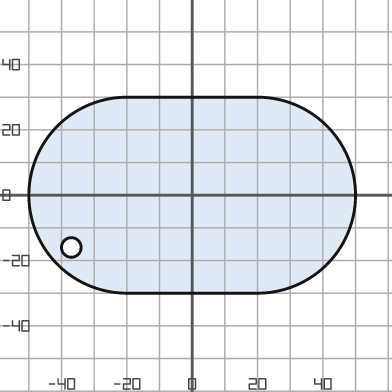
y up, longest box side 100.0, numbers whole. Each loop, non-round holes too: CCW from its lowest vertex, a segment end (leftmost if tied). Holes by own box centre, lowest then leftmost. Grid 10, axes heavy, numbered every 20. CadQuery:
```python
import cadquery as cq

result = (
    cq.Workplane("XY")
    .moveTo(-20.0, -30.0)
    .lineTo(20.0, -30.0)
    .threePointArc((50.0, 0.0), (20.0, 30.0))
    .lineTo(-20.0, 30.0)
    .threePointArc((-50.0, 0.0), (-20.0, -30.0))
    .close()
    .moveTo(-37.0, -16.0)
    .circle(3.0)
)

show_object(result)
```